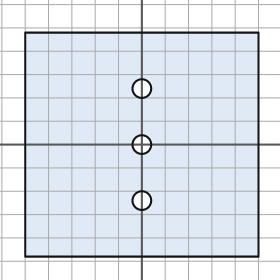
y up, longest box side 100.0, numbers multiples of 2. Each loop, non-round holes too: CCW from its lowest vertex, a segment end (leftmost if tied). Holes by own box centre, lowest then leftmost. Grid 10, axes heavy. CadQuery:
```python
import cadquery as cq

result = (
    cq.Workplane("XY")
    .moveTo(-50.0, -48.0)
    .lineTo(50.0, -48.0)
    .lineTo(50.0, 48.0)
    .lineTo(-50.0, 48.0)
    .close()
    .moveTo(0.0, -24.0)
    .circle(4.0)
    .moveTo(0.0, 0.0)
    .circle(4.0)
    .moveTo(0.0, 24.0)
    .circle(4.0)
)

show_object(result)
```